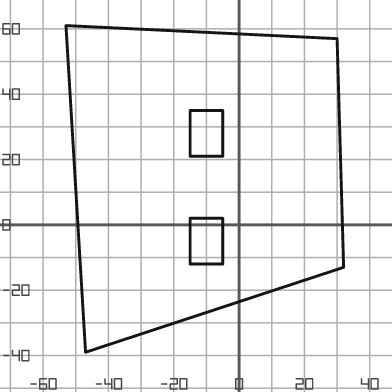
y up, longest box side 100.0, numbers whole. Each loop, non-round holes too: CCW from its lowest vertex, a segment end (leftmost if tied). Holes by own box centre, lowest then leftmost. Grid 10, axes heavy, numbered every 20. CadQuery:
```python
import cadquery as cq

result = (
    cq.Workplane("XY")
    .moveTo(-47.0, -39.0)
    .lineTo(32.0, -13.0)
    .lineTo(30.0, 57.0)
    .lineTo(-53.0, 61.0)
    .close()
    .moveTo(-15.0, -12.0)
    .lineTo(-5.0, -12.0)
    .lineTo(-5.0, 2.0)
    .lineTo(-15.0, 2.0)
    .close()
    .moveTo(-15.0, 21.0)
    .lineTo(-5.0, 21.0)
    .lineTo(-5.0, 35.0)
    .lineTo(-15.0, 35.0)
    .close()
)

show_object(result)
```